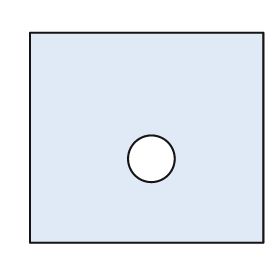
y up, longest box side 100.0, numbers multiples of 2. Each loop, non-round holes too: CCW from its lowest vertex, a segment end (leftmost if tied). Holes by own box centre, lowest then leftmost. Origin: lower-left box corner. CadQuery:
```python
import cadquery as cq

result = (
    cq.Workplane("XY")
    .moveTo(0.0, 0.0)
    .lineTo(100.0, 0.0)
    .lineTo(100.0, 90.0)
    .lineTo(0.0, 90.0)
    .close()
    .moveTo(52.0, 36.0)
    .circle(10.0)
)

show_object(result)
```